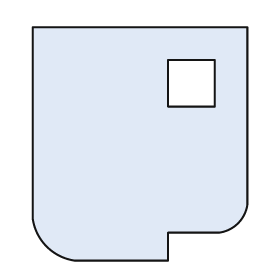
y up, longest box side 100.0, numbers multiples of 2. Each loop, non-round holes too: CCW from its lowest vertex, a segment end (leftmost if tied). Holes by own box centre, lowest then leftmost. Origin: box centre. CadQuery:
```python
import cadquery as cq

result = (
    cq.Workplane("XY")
    .moveTo(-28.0, -50.0)
    .lineTo(12.0, -50.0)
    .lineTo(12.0, -38.0)
    .lineTo(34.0, -38.0)
    .threePointArc((42.0, -34.0), (46.0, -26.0))
    .lineTo(46.0, 50.0)
    .lineTo(-46.0, 50.0)
    .lineTo(-46.0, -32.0)
    .threePointArc((-40.0, -44.0), (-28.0, -50.0))
    .close()
    .moveTo(12.0, 16.0)
    .lineTo(32.0, 16.0)
    .lineTo(32.0, 36.0)
    .lineTo(12.0, 36.0)
    .close()
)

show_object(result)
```